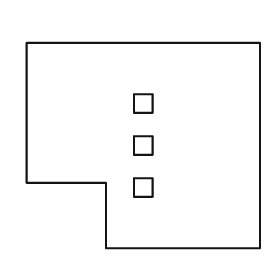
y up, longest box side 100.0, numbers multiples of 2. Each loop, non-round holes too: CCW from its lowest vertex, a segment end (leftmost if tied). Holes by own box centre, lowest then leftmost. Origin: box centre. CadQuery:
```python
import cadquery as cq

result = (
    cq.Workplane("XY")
    .moveTo(-16.0, -44.0)
    .lineTo(50.0, -44.0)
    .lineTo(50.0, 44.0)
    .lineTo(-50.0, 44.0)
    .lineTo(-50.0, -16.0)
    .lineTo(-16.0, -16.0)
    .close()
    .moveTo(-4.0, -22.0)
    .lineTo(4.0, -22.0)
    .lineTo(4.0, -14.0)
    .lineTo(-4.0, -14.0)
    .close()
    .moveTo(-4.0, -4.0)
    .lineTo(4.0, -4.0)
    .lineTo(4.0, 4.0)
    .lineTo(-4.0, 4.0)
    .close()
    .moveTo(-4.0, 14.0)
    .lineTo(4.0, 14.0)
    .lineTo(4.0, 22.0)
    .lineTo(-4.0, 22.0)
    .close()
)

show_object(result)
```